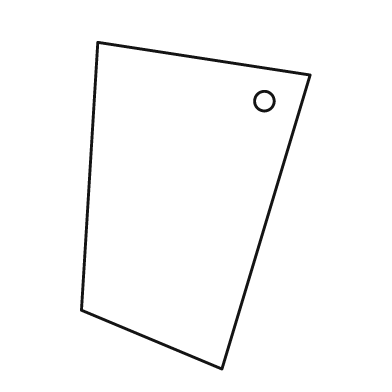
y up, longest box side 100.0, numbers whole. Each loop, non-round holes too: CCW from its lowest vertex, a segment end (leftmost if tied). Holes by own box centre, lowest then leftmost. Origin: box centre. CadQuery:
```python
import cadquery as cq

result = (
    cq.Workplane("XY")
    .moveTo(8.0, -50.0)
    .lineTo(35.0, 40.0)
    .lineTo(-30.0, 50.0)
    .lineTo(-35.0, -32.0)
    .close()
    .moveTo(21.0, 32.0)
    .circle(3.0)
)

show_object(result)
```